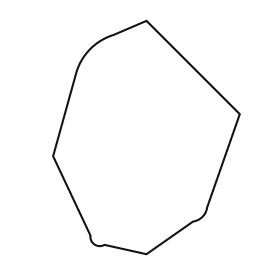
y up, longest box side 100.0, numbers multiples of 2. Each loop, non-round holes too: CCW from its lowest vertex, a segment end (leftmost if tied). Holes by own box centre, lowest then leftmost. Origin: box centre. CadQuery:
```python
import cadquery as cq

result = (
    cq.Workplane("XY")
    .moveTo(0.0, -50.0)
    .lineTo(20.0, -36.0)
    .threePointArc((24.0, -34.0), (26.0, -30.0))
    .lineTo(40.0, 10.0)
    .lineTo(0.0, 50.0)
    .lineTo(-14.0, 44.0)
    .threePointArc((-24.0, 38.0), (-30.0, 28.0))
    .lineTo(-40.0, -8.0)
    .lineTo(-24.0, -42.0)
    .threePointArc((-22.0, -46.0), (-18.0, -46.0))
    .close()
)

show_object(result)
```